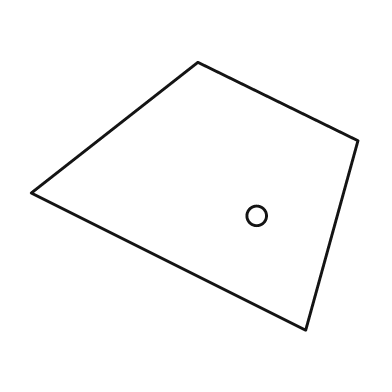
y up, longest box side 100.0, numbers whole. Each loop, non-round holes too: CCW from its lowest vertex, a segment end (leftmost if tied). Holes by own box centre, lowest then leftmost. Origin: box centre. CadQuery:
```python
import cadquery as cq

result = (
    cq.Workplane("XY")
    .moveTo(34.0, -41.0)
    .lineTo(50.0, 17.0)
    .lineTo(1.0, 41.0)
    .lineTo(-50.0, 1.0)
    .close()
    .moveTo(19.0, -6.0)
    .circle(3.0)
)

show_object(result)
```